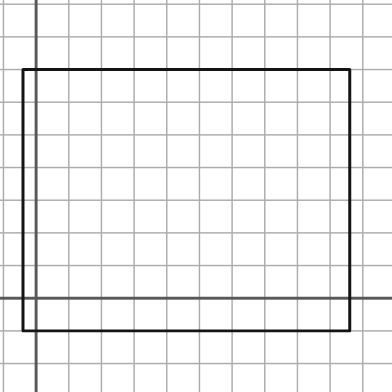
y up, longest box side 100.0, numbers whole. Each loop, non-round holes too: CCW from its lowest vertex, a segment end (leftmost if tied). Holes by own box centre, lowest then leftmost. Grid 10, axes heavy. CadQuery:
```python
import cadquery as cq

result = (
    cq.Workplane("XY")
    .moveTo(-4.0, -10.0)
    .lineTo(96.0, -10.0)
    .lineTo(96.0, 70.0)
    .lineTo(-4.0, 70.0)
    .close()
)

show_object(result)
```